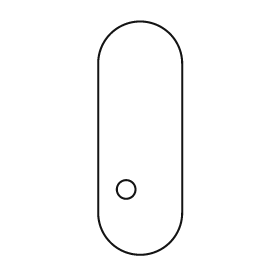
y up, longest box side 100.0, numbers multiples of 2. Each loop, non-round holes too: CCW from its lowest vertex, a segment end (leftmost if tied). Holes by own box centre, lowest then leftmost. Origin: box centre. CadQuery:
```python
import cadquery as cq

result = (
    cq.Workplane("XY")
    .moveTo(-18.0, -32.0)
    .threePointArc((0.0, -50.0), (18.0, -32.0))
    .lineTo(18.0, 32.0)
    .threePointArc((0.0, 50.0), (-18.0, 32.0))
    .close()
    .moveTo(-6.0, -22.0)
    .circle(4.0)
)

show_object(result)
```